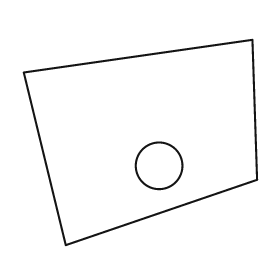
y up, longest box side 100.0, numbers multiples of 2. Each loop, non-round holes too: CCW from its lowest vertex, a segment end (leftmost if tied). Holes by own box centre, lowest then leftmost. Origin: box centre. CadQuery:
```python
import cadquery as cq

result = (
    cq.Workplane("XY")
    .moveTo(-32.0, -44.0)
    .lineTo(50.0, -16.0)
    .lineTo(48.0, 44.0)
    .lineTo(-50.0, 30.0)
    .close()
    .moveTo(8.0, -10.0)
    .circle(10.0)
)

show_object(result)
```